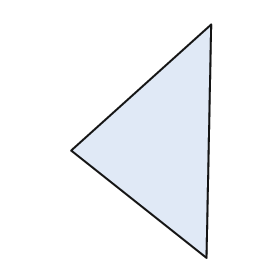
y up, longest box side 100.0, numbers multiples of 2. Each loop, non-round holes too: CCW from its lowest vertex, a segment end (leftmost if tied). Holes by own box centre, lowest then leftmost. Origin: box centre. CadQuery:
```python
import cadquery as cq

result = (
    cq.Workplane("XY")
    .moveTo(28.0, -50.0)
    .lineTo(30.0, 50.0)
    .lineTo(-30.0, -4.0)
    .close()
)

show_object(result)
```